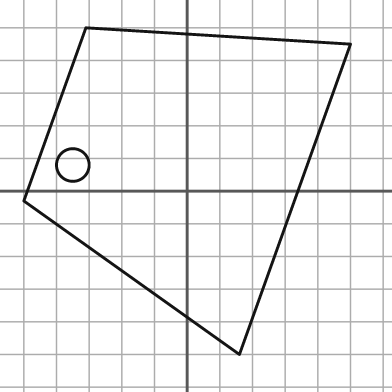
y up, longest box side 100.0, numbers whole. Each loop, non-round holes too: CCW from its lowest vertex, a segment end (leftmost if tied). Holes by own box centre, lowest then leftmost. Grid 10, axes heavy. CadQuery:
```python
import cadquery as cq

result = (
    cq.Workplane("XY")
    .moveTo(16.0, -50.0)
    .lineTo(50.0, 45.0)
    .lineTo(-31.0, 50.0)
    .lineTo(-50.0, -3.0)
    .close()
    .moveTo(-35.0, 8.0)
    .circle(5.0)
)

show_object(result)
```